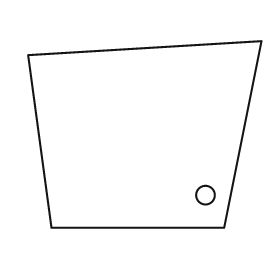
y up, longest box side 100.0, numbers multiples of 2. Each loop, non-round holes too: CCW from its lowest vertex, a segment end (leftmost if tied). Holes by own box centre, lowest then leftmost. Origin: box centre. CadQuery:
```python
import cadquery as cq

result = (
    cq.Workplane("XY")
    .moveTo(-40.0, -40.0)
    .lineTo(34.0, -40.0)
    .lineTo(50.0, 40.0)
    .lineTo(-50.0, 34.0)
    .close()
    .moveTo(26.0, -26.0)
    .circle(4.0)
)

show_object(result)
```